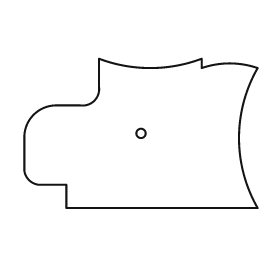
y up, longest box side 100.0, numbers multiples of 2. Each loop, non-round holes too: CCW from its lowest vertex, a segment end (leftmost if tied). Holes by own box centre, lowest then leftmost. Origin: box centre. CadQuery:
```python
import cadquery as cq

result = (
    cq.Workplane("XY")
    .moveTo(-32.0, -32.0)
    .lineTo(50.0, -32.0)
    .threePointArc((42.0, -2.0), (50.0, 28.0))
    .threePointArc((38.0, 30.0), (26.0, 28.0))
    .lineTo(26.0, 32.0)
    .threePointArc((4.0, 28.0), (-18.0, 32.0))
    .lineTo(-18.0, 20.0)
    .threePointArc((-20.0, 14.0), (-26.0, 12.0))
    .lineTo(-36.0, 12.0)
    .threePointArc((-46.0, 8.0), (-50.0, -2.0))
    .lineTo(-50.0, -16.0)
    .threePointArc((-48.0, -20.0), (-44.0, -22.0))
    .lineTo(-32.0, -22.0)
    .close()
    .moveTo(0.0, 0.0)
    .circle(2.0)
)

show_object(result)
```